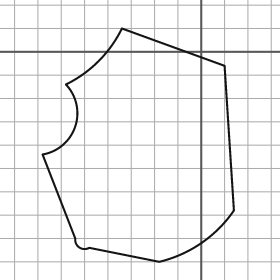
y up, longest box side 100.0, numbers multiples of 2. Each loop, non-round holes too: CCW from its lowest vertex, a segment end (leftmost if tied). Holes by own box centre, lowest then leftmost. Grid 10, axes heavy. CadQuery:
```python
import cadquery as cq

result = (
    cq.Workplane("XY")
    .moveTo(-18.0, -90.0)
    .threePointArc((0.0, -82.0), (14.0, -68.0))
    .lineTo(10.0, -6.0)
    .lineTo(-34.0, 10.0)
    .threePointArc((-44.0, -4.0), (-58.0, -14.0))
    .threePointArc((-54.0, -32.0), (-68.0, -44.0))
    .lineTo(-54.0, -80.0)
    .threePointArc((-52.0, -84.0), (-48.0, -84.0))
    .close()
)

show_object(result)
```